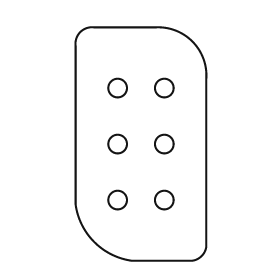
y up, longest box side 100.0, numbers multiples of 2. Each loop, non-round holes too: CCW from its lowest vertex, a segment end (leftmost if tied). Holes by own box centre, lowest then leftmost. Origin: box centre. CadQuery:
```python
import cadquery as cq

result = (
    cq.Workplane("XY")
    .moveTo(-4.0, -50.0)
    .lineTo(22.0, -50.0)
    .threePointArc((26.0, -48.0), (28.0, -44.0))
    .lineTo(28.0, 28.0)
    .threePointArc((22.0, 44.0), (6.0, 50.0))
    .lineTo(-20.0, 50.0)
    .threePointArc((-26.0, 48.0), (-28.0, 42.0))
    .lineTo(-28.0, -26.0)
    .threePointArc((-20.0, -42.0), (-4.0, -50.0))
    .close()
    .moveTo(-10.0, -24.0)
    .circle(4.0)
    .moveTo(10.0, -24.0)
    .circle(4.0)
    .moveTo(-10.0, 0.0)
    .circle(4.0)
    .moveTo(10.0, 0.0)
    .circle(4.0)
    .moveTo(-10.0, 24.0)
    .circle(4.0)
    .moveTo(10.0, 24.0)
    .circle(4.0)
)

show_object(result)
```